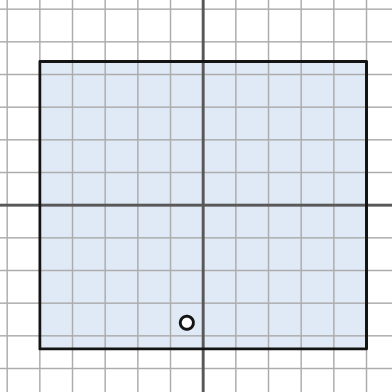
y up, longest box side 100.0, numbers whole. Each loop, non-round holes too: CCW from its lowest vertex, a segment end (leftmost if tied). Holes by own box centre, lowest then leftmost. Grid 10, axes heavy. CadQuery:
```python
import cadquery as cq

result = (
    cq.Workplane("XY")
    .moveTo(-50.0, -44.0)
    .lineTo(50.0, -44.0)
    .lineTo(50.0, 44.0)
    .lineTo(-50.0, 44.0)
    .close()
    .moveTo(-5.0, -36.0)
    .circle(2.0)
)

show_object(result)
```